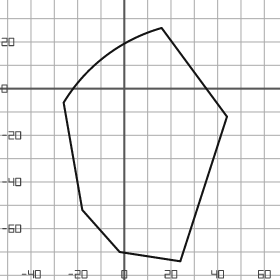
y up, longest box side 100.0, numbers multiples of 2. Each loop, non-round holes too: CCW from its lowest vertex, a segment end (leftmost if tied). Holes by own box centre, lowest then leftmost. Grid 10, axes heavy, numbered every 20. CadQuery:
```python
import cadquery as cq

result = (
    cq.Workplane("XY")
    .moveTo(24.0, -74.0)
    .lineTo(44.0, -12.0)
    .lineTo(16.0, 26.0)
    .threePointArc((-8.0, 14.0), (-26.0, -6.0))
    .lineTo(-18.0, -52.0)
    .lineTo(-2.0, -70.0)
    .close()
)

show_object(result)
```